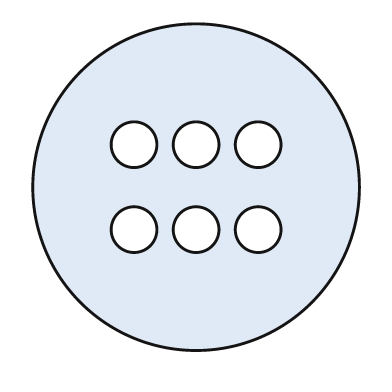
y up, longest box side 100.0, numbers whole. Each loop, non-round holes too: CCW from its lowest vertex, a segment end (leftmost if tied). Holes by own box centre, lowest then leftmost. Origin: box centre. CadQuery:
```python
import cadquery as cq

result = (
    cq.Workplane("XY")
    .moveTo(0.0, 0.0)
    .circle(50.0)
    .moveTo(-19.0, -13.0)
    .circle(7.0)
    .moveTo(0.0, -13.0)
    .circle(7.0)
    .moveTo(19.0, -13.0)
    .circle(7.0)
    .moveTo(-19.0, 13.0)
    .circle(7.0)
    .moveTo(0.0, 13.0)
    .circle(7.0)
    .moveTo(19.0, 13.0)
    .circle(7.0)
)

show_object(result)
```